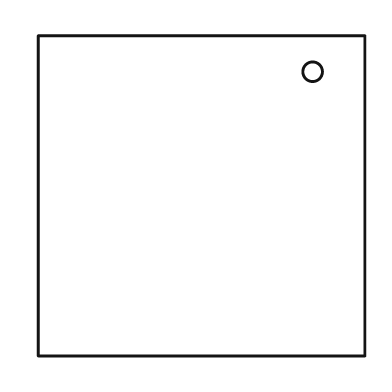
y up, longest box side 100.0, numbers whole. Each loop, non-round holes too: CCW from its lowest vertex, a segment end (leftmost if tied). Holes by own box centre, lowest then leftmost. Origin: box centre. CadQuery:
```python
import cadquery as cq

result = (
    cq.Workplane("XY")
    .moveTo(-50.0, -49.0)
    .lineTo(50.0, -49.0)
    .lineTo(50.0, 49.0)
    .lineTo(-50.0, 49.0)
    .close()
    .moveTo(34.0, 38.0)
    .circle(3.0)
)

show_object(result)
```